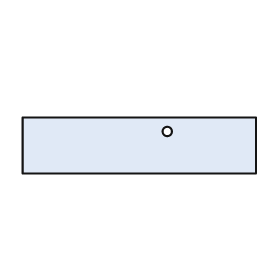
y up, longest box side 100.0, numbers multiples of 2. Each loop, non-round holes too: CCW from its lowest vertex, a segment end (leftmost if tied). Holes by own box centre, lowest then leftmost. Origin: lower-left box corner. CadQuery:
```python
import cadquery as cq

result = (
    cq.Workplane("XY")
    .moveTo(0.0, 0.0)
    .lineTo(100.0, 0.0)
    .lineTo(100.0, 24.0)
    .lineTo(0.0, 24.0)
    .close()
    .moveTo(62.0, 18.0)
    .circle(2.0)
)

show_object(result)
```